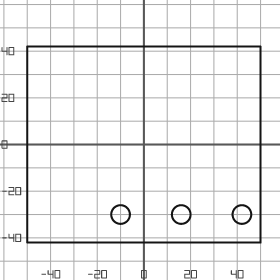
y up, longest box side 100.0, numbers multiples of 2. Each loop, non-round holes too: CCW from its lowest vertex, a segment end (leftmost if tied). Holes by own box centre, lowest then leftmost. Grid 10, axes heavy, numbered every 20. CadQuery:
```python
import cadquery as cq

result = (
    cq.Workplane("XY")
    .moveTo(-50.0, -42.0)
    .lineTo(50.0, -42.0)
    .lineTo(50.0, 42.0)
    .lineTo(-50.0, 42.0)
    .close()
    .moveTo(-10.0, -30.0)
    .circle(4.0)
    .moveTo(16.0, -30.0)
    .circle(4.0)
    .moveTo(42.0, -30.0)
    .circle(4.0)
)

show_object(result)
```